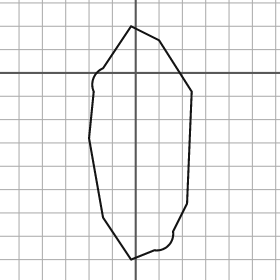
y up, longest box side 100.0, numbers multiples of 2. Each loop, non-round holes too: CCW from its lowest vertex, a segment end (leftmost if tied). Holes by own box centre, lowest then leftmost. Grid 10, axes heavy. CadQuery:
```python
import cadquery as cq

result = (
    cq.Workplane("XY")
    .moveTo(-2.0, -80.0)
    .lineTo(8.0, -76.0)
    .threePointArc((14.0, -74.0), (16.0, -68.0))
    .lineTo(22.0, -56.0)
    .lineTo(24.0, -8.0)
    .lineTo(10.0, 14.0)
    .lineTo(-2.0, 20.0)
    .lineTo(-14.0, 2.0)
    .threePointArc((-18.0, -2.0), (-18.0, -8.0))
    .lineTo(-20.0, -28.0)
    .lineTo(-14.0, -62.0)
    .close()
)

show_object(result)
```